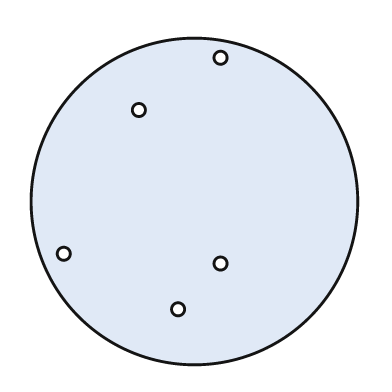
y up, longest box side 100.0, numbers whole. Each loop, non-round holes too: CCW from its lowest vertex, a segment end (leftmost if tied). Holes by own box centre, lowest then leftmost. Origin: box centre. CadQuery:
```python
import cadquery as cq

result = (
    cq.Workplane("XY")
    .moveTo(0.0, 0.0)
    .circle(50.0)
    .moveTo(-5.0, -33.0)
    .circle(2.0)
    .moveTo(8.0, -19.0)
    .circle(2.0)
    .moveTo(-40.0, -16.0)
    .circle(2.0)
    .moveTo(-17.0, 28.0)
    .circle(2.0)
    .moveTo(8.0, 44.0)
    .circle(2.0)
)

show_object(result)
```